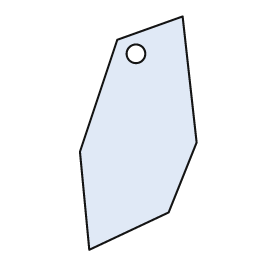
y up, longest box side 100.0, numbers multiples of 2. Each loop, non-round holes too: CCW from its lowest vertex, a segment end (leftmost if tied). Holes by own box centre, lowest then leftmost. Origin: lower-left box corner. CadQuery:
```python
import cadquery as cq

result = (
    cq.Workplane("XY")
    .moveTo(4.0, 0.0)
    .lineTo(38.0, 16.0)
    .lineTo(50.0, 46.0)
    .lineTo(44.0, 100.0)
    .lineTo(16.0, 90.0)
    .lineTo(0.0, 42.0)
    .close()
    .moveTo(24.0, 84.0)
    .circle(4.0)
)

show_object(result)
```